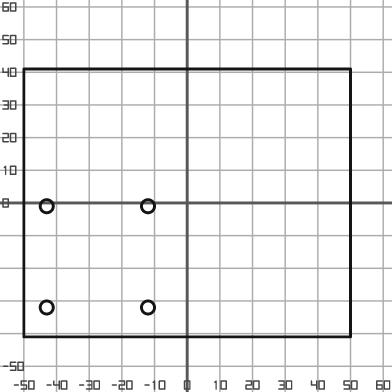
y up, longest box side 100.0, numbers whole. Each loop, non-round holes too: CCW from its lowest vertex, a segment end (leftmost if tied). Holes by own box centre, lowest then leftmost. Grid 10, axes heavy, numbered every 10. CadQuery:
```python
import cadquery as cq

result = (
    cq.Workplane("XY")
    .moveTo(-50.0, -41.0)
    .lineTo(50.0, -41.0)
    .lineTo(50.0, 41.0)
    .lineTo(-50.0, 41.0)
    .close()
    .moveTo(-43.0, -32.0)
    .circle(2.0)
    .moveTo(-12.0, -32.0)
    .circle(2.0)
    .moveTo(-43.0, -1.0)
    .circle(2.0)
    .moveTo(-12.0, -1.0)
    .circle(2.0)
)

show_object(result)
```